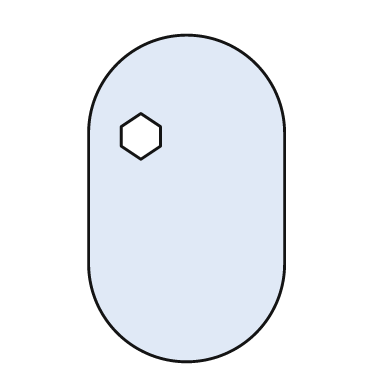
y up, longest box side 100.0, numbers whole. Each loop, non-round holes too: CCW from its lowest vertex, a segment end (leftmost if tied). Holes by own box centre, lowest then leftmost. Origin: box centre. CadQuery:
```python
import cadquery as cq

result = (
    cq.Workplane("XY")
    .moveTo(-30.0, -20.0)
    .threePointArc((0.0, -50.0), (30.0, -20.0))
    .lineTo(30.0, 20.0)
    .threePointArc((0.0, 50.0), (-30.0, 20.0))
    .close()
    .moveTo(-14.0, 12.0)
    .lineTo(-8.0, 16.0)
    .lineTo(-8.0, 22.0)
    .lineTo(-14.0, 26.0)
    .lineTo(-20.0, 22.0)
    .lineTo(-20.0, 16.0)
    .close()
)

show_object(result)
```